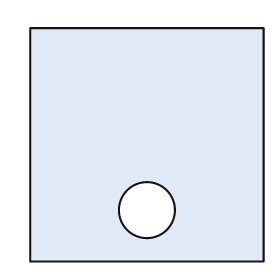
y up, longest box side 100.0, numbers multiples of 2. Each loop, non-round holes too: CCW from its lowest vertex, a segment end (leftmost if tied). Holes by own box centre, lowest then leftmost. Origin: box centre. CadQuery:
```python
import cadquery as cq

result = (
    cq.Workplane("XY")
    .moveTo(-50.0, -50.0)
    .lineTo(50.0, -50.0)
    .lineTo(50.0, 50.0)
    .lineTo(-50.0, 50.0)
    .close()
    .moveTo(0.0, -28.0)
    .circle(12.0)
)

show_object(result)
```